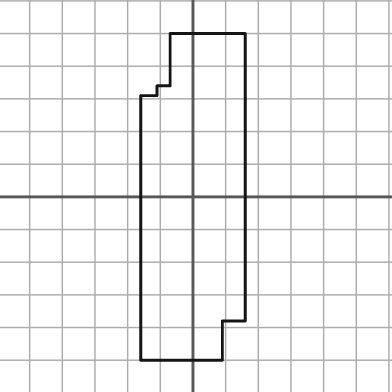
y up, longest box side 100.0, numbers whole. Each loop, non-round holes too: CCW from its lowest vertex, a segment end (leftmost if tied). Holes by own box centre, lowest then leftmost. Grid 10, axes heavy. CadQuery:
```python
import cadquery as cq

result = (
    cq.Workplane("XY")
    .moveTo(-16.0, -50.0)
    .lineTo(9.0, -50.0)
    .lineTo(9.0, -38.0)
    .lineTo(16.0, -38.0)
    .lineTo(16.0, 50.0)
    .lineTo(-7.0, 50.0)
    .lineTo(-7.0, 34.0)
    .lineTo(-11.0, 34.0)
    .lineTo(-11.0, 31.0)
    .lineTo(-16.0, 31.0)
    .close()
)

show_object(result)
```